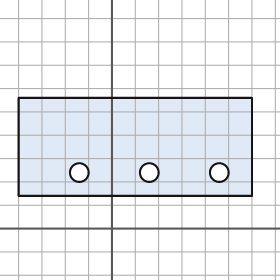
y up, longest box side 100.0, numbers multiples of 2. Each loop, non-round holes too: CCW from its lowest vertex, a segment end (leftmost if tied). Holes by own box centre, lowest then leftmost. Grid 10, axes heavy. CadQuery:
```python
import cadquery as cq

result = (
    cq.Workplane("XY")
    .moveTo(-40.0, 14.0)
    .lineTo(60.0, 14.0)
    .lineTo(60.0, 56.0)
    .lineTo(-40.0, 56.0)
    .close()
    .moveTo(-14.0, 24.0)
    .circle(4.0)
    .moveTo(16.0, 24.0)
    .circle(4.0)
    .moveTo(46.0, 24.0)
    .circle(4.0)
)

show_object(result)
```